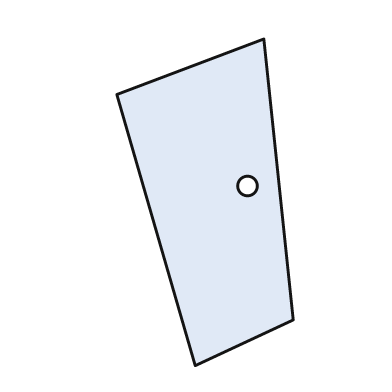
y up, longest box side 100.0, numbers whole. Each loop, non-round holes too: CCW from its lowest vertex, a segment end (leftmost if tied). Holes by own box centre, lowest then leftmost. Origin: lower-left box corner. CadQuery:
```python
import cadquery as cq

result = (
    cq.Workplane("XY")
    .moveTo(24.0, 0.0)
    .lineTo(54.0, 14.0)
    .lineTo(45.0, 100.0)
    .lineTo(0.0, 83.0)
    .close()
    .moveTo(40.0, 55.0)
    .circle(3.0)
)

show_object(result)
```